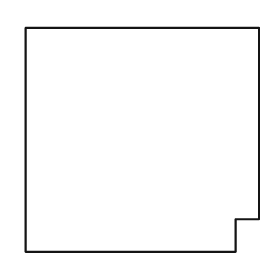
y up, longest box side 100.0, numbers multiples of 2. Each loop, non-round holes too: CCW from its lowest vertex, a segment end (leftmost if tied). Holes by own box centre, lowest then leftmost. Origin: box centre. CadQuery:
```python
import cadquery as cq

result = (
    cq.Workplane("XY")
    .moveTo(-50.0, -48.0)
    .lineTo(40.0, -48.0)
    .lineTo(40.0, -34.0)
    .lineTo(50.0, -34.0)
    .lineTo(50.0, 48.0)
    .lineTo(-50.0, 48.0)
    .close()
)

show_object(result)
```